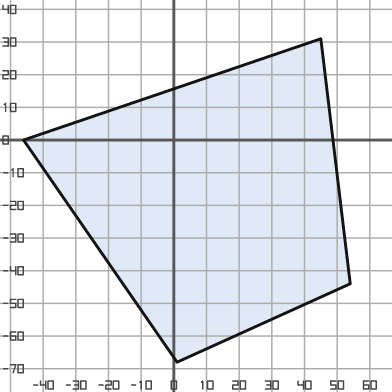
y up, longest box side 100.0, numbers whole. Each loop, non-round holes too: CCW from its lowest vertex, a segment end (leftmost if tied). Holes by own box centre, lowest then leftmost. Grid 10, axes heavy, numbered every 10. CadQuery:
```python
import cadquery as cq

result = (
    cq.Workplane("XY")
    .moveTo(1.0, -68.0)
    .lineTo(54.0, -44.0)
    .lineTo(45.0, 31.0)
    .lineTo(-46.0, 0.0)
    .close()
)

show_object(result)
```